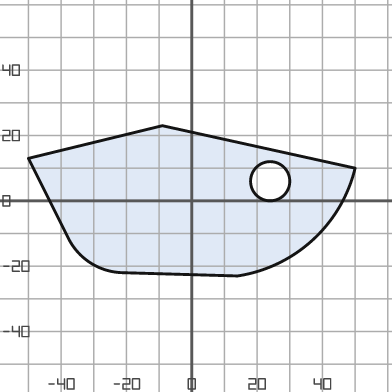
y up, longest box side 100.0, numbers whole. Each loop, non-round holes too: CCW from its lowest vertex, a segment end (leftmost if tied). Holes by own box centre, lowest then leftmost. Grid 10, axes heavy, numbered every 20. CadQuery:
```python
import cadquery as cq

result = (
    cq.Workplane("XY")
    .moveTo(14.0, -23.0)
    .threePointArc((37.0, -12.0), (50.0, 10.0))
    .lineTo(-9.0, 23.0)
    .lineTo(-50.0, 13.0)
    .lineTo(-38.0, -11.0)
    .threePointArc((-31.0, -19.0), (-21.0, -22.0))
    .close()
    .moveTo(24.0, 6.0)
    .circle(6.0)
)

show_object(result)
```